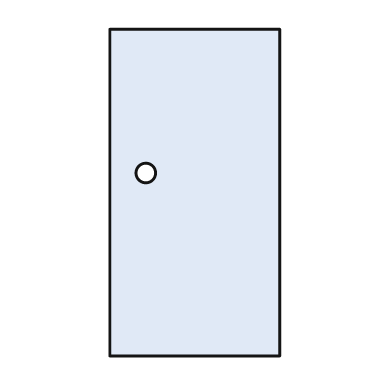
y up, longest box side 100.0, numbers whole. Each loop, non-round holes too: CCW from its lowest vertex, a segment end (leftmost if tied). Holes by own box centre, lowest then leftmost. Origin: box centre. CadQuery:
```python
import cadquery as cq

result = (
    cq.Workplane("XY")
    .moveTo(-26.0, -50.0)
    .lineTo(26.0, -50.0)
    .lineTo(26.0, 50.0)
    .lineTo(-26.0, 50.0)
    .close()
    .moveTo(-15.0, 6.0)
    .circle(3.0)
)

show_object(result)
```